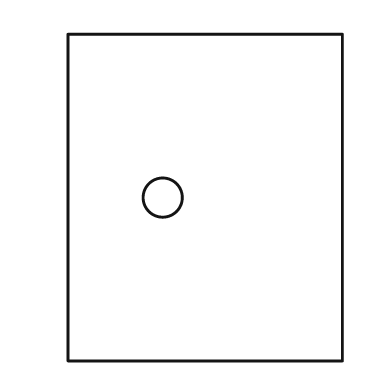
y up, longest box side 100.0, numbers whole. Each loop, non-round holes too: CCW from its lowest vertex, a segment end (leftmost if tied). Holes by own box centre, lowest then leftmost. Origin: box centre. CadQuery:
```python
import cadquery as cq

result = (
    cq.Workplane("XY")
    .moveTo(-42.0, -50.0)
    .lineTo(42.0, -50.0)
    .lineTo(42.0, 50.0)
    .lineTo(-42.0, 50.0)
    .close()
    .moveTo(-13.0, 0.0)
    .circle(6.0)
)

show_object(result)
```